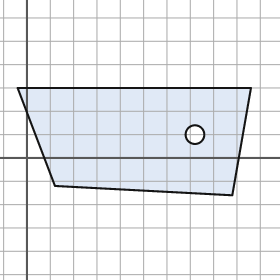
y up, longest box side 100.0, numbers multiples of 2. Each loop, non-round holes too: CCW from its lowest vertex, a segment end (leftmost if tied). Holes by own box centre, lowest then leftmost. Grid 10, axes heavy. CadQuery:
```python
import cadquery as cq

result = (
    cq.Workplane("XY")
    .moveTo(88.0, -16.0)
    .lineTo(96.0, 30.0)
    .lineTo(-4.0, 30.0)
    .lineTo(12.0, -12.0)
    .close()
    .moveTo(72.0, 10.0)
    .circle(4.0)
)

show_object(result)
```